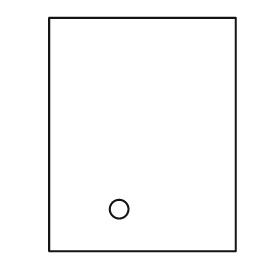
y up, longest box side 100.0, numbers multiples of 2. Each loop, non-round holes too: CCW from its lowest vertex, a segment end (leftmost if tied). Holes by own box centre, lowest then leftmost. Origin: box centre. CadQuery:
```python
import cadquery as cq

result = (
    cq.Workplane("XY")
    .moveTo(-40.0, -50.0)
    .lineTo(40.0, -50.0)
    .lineTo(40.0, 50.0)
    .lineTo(-40.0, 50.0)
    .close()
    .moveTo(-10.0, -32.0)
    .circle(4.0)
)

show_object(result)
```